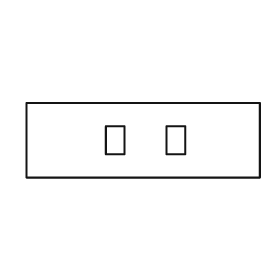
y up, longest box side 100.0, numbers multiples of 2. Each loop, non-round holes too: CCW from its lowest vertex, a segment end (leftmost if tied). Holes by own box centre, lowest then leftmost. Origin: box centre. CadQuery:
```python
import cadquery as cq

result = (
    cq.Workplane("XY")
    .moveTo(-50.0, -16.0)
    .lineTo(50.0, -16.0)
    .lineTo(50.0, 16.0)
    .lineTo(-50.0, 16.0)
    .close()
    .moveTo(-16.0, -6.0)
    .lineTo(-8.0, -6.0)
    .lineTo(-8.0, 6.0)
    .lineTo(-16.0, 6.0)
    .close()
    .moveTo(10.0, -6.0)
    .lineTo(18.0, -6.0)
    .lineTo(18.0, 6.0)
    .lineTo(10.0, 6.0)
    .close()
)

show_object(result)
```